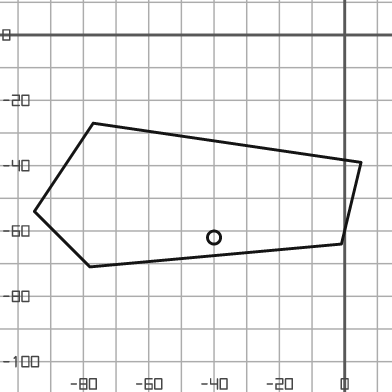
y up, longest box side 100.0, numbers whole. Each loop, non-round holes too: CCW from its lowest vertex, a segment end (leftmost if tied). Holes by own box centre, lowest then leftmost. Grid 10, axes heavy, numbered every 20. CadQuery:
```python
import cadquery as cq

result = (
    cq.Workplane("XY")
    .moveTo(-78.0, -71.0)
    .lineTo(-1.0, -64.0)
    .lineTo(5.0, -39.0)
    .lineTo(-77.0, -27.0)
    .lineTo(-95.0, -54.0)
    .close()
    .moveTo(-40.0, -62.0)
    .circle(2.0)
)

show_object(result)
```